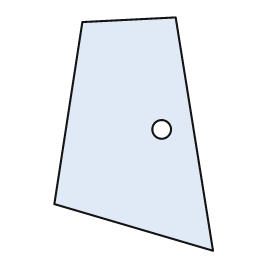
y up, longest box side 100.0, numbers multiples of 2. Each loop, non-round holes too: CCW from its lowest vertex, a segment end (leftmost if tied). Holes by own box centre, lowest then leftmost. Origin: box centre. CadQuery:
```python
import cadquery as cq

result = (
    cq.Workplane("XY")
    .moveTo(34.0, -50.0)
    .lineTo(18.0, 50.0)
    .lineTo(-22.0, 48.0)
    .lineTo(-34.0, -30.0)
    .close()
    .moveTo(12.0, 2.0)
    .circle(4.0)
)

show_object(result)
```